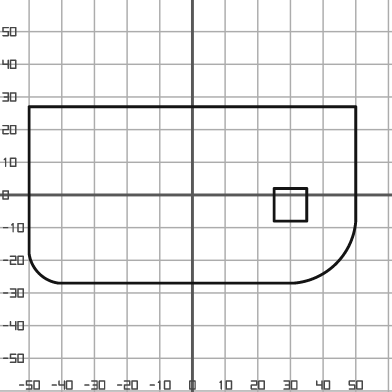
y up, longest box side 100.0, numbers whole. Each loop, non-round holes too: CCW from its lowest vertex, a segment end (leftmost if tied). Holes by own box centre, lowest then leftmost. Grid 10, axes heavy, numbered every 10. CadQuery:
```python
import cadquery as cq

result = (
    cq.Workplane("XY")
    .moveTo(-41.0, -27.0)
    .lineTo(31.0, -27.0)
    .threePointArc((44.0, -21.0), (50.0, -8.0))
    .lineTo(50.0, 27.0)
    .lineTo(-50.0, 27.0)
    .lineTo(-50.0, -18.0)
    .threePointArc((-47.0, -24.0), (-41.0, -27.0))
    .close()
    .moveTo(25.0, -8.0)
    .lineTo(35.0, -8.0)
    .lineTo(35.0, 2.0)
    .lineTo(25.0, 2.0)
    .close()
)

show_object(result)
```